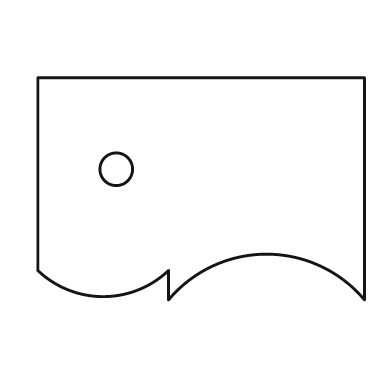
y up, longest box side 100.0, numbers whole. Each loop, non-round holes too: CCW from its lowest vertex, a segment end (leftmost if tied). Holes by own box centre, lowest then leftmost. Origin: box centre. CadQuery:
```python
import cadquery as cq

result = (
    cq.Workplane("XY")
    .moveTo(-10.0, -34.0)
    .threePointArc((20.0, -20.0), (50.0, -34.0))
    .lineTo(50.0, 34.0)
    .lineTo(-50.0, 34.0)
    .lineTo(-50.0, -25.0)
    .threePointArc((-30.0, -33.0), (-10.0, -25.0))
    .close()
    .moveTo(-26.0, 6.0)
    .circle(5.0)
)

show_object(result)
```